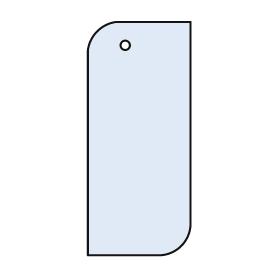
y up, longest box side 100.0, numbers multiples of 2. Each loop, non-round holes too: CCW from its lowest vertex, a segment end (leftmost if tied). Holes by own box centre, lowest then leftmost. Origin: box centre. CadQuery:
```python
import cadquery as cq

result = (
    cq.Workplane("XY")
    .moveTo(-22.0, -50.0)
    .lineTo(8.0, -50.0)
    .threePointArc((18.0, -46.0), (22.0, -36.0))
    .lineTo(22.0, 50.0)
    .lineTo(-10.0, 50.0)
    .threePointArc((-18.0, 46.0), (-22.0, 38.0))
    .close()
    .moveTo(-6.0, 40.0)
    .circle(2.0)
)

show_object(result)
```